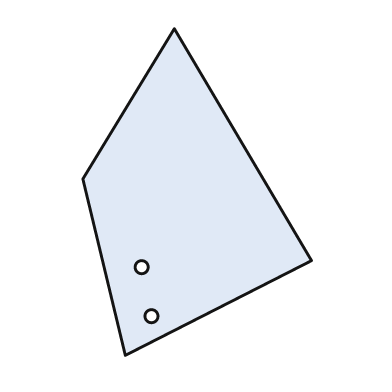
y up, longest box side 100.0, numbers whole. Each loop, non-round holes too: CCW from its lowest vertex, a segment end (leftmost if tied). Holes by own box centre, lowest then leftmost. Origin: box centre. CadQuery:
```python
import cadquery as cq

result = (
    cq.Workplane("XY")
    .moveTo(-22.0, -50.0)
    .lineTo(35.0, -21.0)
    .lineTo(-7.0, 50.0)
    .lineTo(-35.0, 4.0)
    .close()
    .moveTo(-14.0, -38.0)
    .circle(2.0)
    .moveTo(-17.0, -23.0)
    .circle(2.0)
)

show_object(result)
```